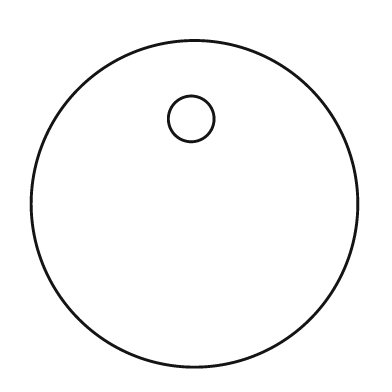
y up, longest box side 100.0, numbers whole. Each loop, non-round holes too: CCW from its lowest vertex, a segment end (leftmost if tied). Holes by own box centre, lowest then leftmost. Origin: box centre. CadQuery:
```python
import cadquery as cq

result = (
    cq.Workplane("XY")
    .moveTo(0.0, 0.0)
    .circle(50.0)
    .moveTo(-1.0, 26.0)
    .circle(7.0)
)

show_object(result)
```